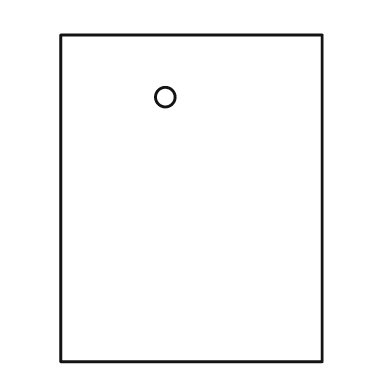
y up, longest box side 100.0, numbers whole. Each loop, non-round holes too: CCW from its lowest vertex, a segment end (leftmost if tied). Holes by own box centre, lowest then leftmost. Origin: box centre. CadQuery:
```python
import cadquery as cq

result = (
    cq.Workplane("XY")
    .moveTo(-40.0, -50.0)
    .lineTo(40.0, -50.0)
    .lineTo(40.0, 50.0)
    .lineTo(-40.0, 50.0)
    .close()
    .moveTo(-8.0, 31.0)
    .circle(3.0)
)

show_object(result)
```